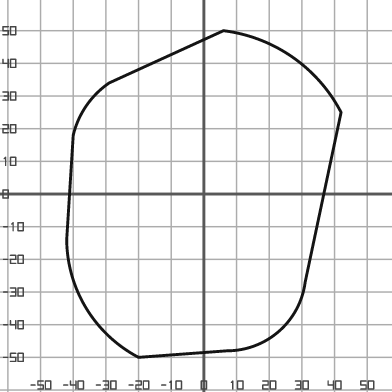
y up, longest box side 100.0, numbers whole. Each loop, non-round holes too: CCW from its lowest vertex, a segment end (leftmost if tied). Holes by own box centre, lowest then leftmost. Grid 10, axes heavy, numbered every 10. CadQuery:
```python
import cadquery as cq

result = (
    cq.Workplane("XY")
    .moveTo(-20.0, -50.0)
    .lineTo(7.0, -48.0)
    .threePointArc((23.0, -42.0), (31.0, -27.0))
    .lineTo(42.0, 25.0)
    .threePointArc((27.0, 42.0), (6.0, 50.0))
    .lineTo(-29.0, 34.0)
    .threePointArc((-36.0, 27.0), (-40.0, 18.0))
    .lineTo(-42.0, -14.0)
    .threePointArc((-36.0, -35.0), (-20.0, -50.0))
    .close()
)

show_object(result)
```